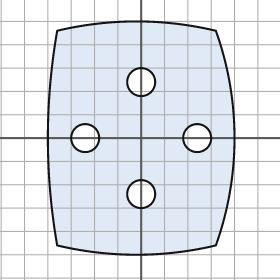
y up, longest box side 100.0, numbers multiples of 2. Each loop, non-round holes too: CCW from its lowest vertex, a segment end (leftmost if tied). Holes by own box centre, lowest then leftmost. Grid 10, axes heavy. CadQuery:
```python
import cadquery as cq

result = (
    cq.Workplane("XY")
    .moveTo(-36.0, -46.0)
    .threePointArc((-2.0, -50.0), (32.0, -46.0))
    .threePointArc((40.0, 0.0), (32.0, 46.0))
    .threePointArc((-2.0, 50.0), (-36.0, 46.0))
    .threePointArc((-40.0, 0.0), (-36.0, -46.0))
    .close()
    .moveTo(0.0, -24.0)
    .circle(6.0)
    .moveTo(-24.0, 0.0)
    .circle(6.0)
    .moveTo(24.0, 0.0)
    .circle(6.0)
    .moveTo(0.0, 24.0)
    .circle(6.0)
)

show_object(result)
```